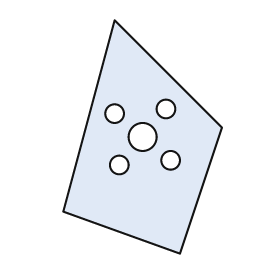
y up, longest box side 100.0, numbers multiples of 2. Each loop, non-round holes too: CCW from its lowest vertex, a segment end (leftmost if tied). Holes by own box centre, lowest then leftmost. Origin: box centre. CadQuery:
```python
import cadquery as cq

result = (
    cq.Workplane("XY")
    .moveTo(16.0, -50.0)
    .lineTo(34.0, 4.0)
    .lineTo(-12.0, 50.0)
    .lineTo(-34.0, -32.0)
    .close()
    .moveTo(-10.0, -12.0)
    .circle(4.0)
    .moveTo(12.0, -10.0)
    .circle(4.0)
    .moveTo(0.0, 0.0)
    .circle(6.0)
    .moveTo(-12.0, 10.0)
    .circle(4.0)
    .moveTo(10.0, 12.0)
    .circle(4.0)
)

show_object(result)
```